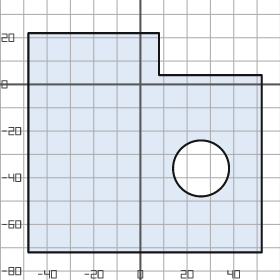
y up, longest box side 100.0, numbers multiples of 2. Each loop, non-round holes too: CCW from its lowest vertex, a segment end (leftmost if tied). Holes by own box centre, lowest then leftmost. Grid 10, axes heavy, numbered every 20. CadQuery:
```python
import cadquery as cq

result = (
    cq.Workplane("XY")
    .moveTo(-48.0, -72.0)
    .lineTo(52.0, -72.0)
    .lineTo(52.0, 4.0)
    .lineTo(8.0, 4.0)
    .lineTo(8.0, 22.0)
    .lineTo(-48.0, 22.0)
    .close()
    .moveTo(26.0, -36.0)
    .circle(12.0)
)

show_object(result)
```